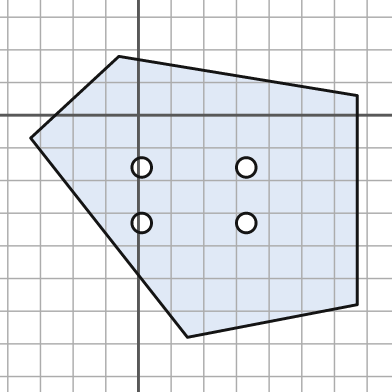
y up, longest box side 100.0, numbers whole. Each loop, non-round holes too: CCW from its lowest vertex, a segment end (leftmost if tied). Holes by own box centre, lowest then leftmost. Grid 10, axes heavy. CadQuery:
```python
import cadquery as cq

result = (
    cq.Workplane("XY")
    .moveTo(15.0, -68.0)
    .lineTo(67.0, -58.0)
    .lineTo(67.0, 6.0)
    .lineTo(-6.0, 18.0)
    .lineTo(-33.0, -7.0)
    .close()
    .moveTo(1.0, -33.0)
    .circle(3.0)
    .moveTo(33.0, -33.0)
    .circle(3.0)
    .moveTo(1.0, -16.0)
    .circle(3.0)
    .moveTo(33.0, -16.0)
    .circle(3.0)
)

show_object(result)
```